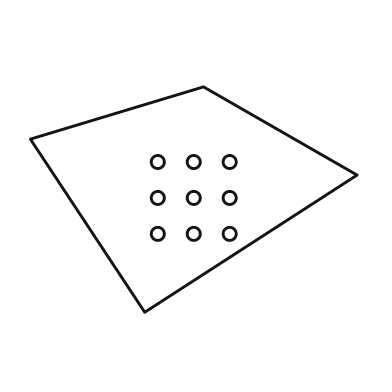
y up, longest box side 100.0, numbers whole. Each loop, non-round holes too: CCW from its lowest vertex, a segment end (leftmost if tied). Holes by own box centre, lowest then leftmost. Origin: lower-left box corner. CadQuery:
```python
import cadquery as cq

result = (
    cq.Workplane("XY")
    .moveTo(35.0, 0.0)
    .lineTo(100.0, 42.0)
    .lineTo(53.0, 69.0)
    .lineTo(0.0, 53.0)
    .close()
    .moveTo(39.0, 24.0)
    .circle(2.0)
    .moveTo(50.0, 24.0)
    .circle(2.0)
    .moveTo(61.0, 24.0)
    .circle(2.0)
    .moveTo(39.0, 35.0)
    .circle(2.0)
    .moveTo(50.0, 35.0)
    .circle(2.0)
    .moveTo(61.0, 35.0)
    .circle(2.0)
    .moveTo(39.0, 46.0)
    .circle(2.0)
    .moveTo(50.0, 46.0)
    .circle(2.0)
    .moveTo(61.0, 46.0)
    .circle(2.0)
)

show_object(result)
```